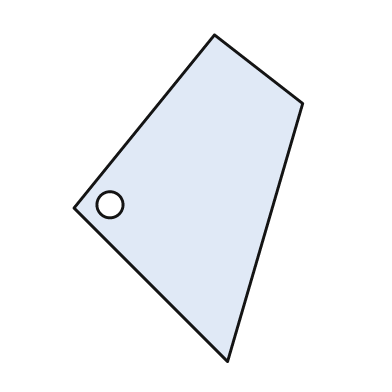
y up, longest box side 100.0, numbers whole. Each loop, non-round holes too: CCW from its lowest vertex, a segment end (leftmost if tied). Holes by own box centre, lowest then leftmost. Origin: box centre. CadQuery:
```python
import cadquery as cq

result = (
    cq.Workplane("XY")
    .moveTo(12.0, -50.0)
    .lineTo(35.0, 29.0)
    .lineTo(8.0, 50.0)
    .lineTo(-35.0, -3.0)
    .close()
    .moveTo(-24.0, -2.0)
    .circle(4.0)
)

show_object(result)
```